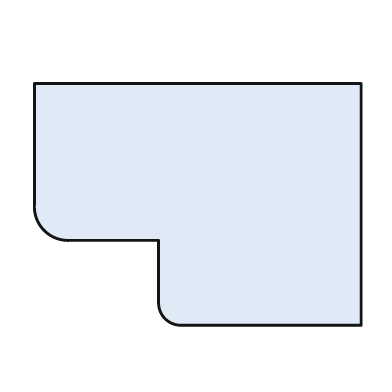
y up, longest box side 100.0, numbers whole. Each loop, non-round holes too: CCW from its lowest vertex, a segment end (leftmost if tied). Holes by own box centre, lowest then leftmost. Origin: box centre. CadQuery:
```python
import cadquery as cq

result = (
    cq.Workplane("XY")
    .moveTo(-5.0, -37.0)
    .lineTo(50.0, -37.0)
    .lineTo(50.0, 37.0)
    .lineTo(-50.0, 37.0)
    .lineTo(-50.0, 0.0)
    .threePointArc((-47.0, -8.0), (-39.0, -11.0))
    .lineTo(-12.0, -11.0)
    .lineTo(-12.0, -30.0)
    .threePointArc((-10.0, -35.0), (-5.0, -37.0))
    .close()
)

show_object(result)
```